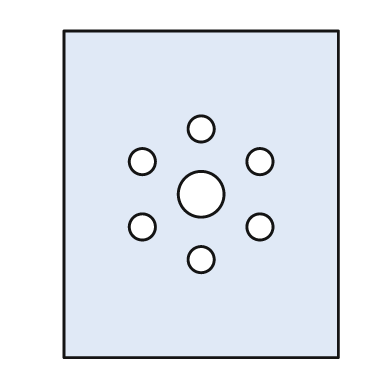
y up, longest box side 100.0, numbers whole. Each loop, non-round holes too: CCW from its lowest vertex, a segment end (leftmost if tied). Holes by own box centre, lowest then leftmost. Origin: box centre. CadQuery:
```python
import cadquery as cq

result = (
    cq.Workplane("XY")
    .moveTo(-42.0, -50.0)
    .lineTo(42.0, -50.0)
    .lineTo(42.0, 50.0)
    .lineTo(-42.0, 50.0)
    .close()
    .moveTo(0.0, -20.0)
    .circle(4.0)
    .moveTo(-18.0, -10.0)
    .circle(4.0)
    .moveTo(18.0, -10.0)
    .circle(4.0)
    .moveTo(0.0, 0.0)
    .circle(7.0)
    .moveTo(-18.0, 10.0)
    .circle(4.0)
    .moveTo(18.0, 10.0)
    .circle(4.0)
    .moveTo(0.0, 20.0)
    .circle(4.0)
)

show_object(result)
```